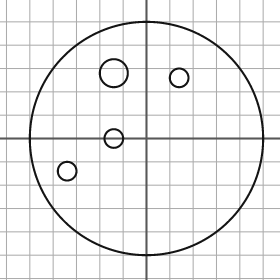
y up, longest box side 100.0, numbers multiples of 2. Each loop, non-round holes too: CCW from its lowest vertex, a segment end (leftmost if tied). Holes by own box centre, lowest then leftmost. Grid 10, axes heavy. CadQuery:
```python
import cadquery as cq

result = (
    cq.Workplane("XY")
    .moveTo(0.0, 0.0)
    .circle(50.0)
    .moveTo(-34.0, -14.0)
    .circle(4.0)
    .moveTo(-14.0, 0.0)
    .circle(4.0)
    .moveTo(14.0, 26.0)
    .circle(4.0)
    .moveTo(-14.0, 28.0)
    .circle(6.0)
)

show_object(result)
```